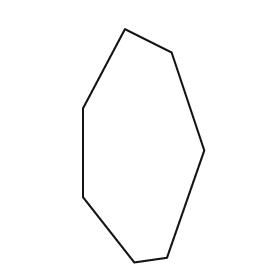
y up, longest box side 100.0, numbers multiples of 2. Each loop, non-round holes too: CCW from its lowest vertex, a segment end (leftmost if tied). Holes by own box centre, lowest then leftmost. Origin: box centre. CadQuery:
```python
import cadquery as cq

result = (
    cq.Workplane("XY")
    .moveTo(-4.0, -50.0)
    .lineTo(10.0, -48.0)
    .lineTo(26.0, -2.0)
    .lineTo(12.0, 40.0)
    .lineTo(-8.0, 50.0)
    .lineTo(-26.0, 16.0)
    .lineTo(-26.0, -22.0)
    .close()
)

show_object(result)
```